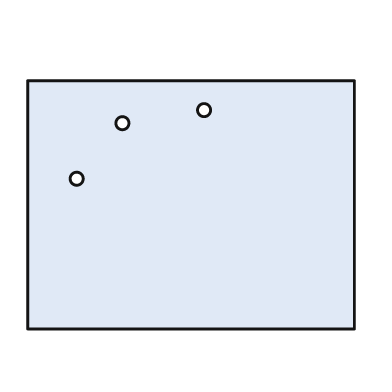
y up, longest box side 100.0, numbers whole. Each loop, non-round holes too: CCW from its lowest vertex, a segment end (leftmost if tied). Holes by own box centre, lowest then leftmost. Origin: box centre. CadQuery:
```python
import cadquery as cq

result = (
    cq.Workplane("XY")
    .moveTo(-50.0, -38.0)
    .lineTo(50.0, -38.0)
    .lineTo(50.0, 38.0)
    .lineTo(-50.0, 38.0)
    .close()
    .moveTo(-35.0, 8.0)
    .circle(2.0)
    .moveTo(-21.0, 25.0)
    .circle(2.0)
    .moveTo(4.0, 29.0)
    .circle(2.0)
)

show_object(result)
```